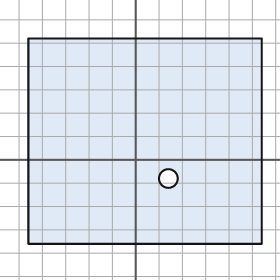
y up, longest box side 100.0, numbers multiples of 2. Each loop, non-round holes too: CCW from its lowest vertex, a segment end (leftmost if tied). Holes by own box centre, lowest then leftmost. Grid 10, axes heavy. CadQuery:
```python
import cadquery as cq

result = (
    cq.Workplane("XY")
    .moveTo(-46.0, -36.0)
    .lineTo(54.0, -36.0)
    .lineTo(54.0, 52.0)
    .lineTo(-46.0, 52.0)
    .close()
    .moveTo(14.0, -8.0)
    .circle(4.0)
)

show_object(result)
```